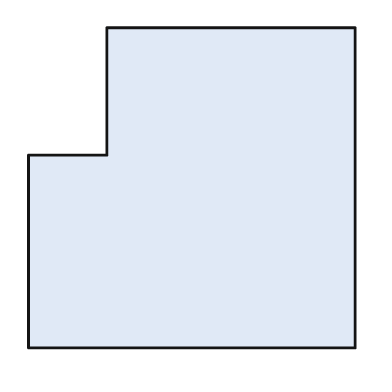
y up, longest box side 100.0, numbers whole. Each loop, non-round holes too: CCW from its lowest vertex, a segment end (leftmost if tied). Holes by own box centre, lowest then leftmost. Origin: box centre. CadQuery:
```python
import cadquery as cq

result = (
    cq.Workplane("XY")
    .moveTo(-50.0, -49.0)
    .lineTo(50.0, -49.0)
    .lineTo(50.0, 49.0)
    .lineTo(-26.0, 49.0)
    .lineTo(-26.0, 10.0)
    .lineTo(-50.0, 10.0)
    .close()
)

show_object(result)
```